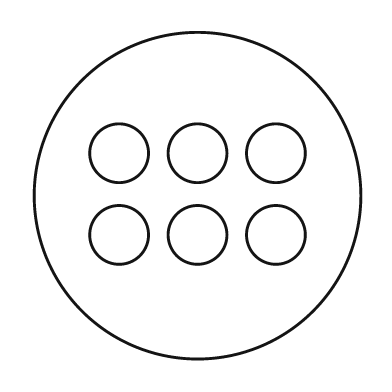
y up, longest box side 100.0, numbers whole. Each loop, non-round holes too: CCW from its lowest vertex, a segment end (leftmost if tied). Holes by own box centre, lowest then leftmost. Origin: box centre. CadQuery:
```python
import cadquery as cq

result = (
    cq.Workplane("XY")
    .moveTo(0.0, 0.0)
    .circle(50.0)
    .moveTo(-24.0, -12.0)
    .circle(9.0)
    .moveTo(0.0, -12.0)
    .circle(9.0)
    .moveTo(24.0, -12.0)
    .circle(9.0)
    .moveTo(-24.0, 13.0)
    .circle(9.0)
    .moveTo(0.0, 13.0)
    .circle(9.0)
    .moveTo(24.0, 13.0)
    .circle(9.0)
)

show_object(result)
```